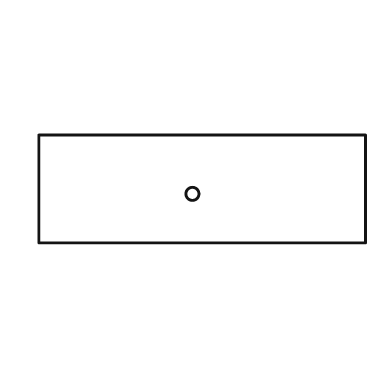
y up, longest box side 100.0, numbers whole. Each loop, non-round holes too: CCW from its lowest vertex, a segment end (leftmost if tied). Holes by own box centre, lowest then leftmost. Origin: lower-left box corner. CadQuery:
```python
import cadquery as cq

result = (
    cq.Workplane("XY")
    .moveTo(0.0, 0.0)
    .lineTo(100.0, 0.0)
    .lineTo(100.0, 33.0)
    .lineTo(0.0, 33.0)
    .close()
    .moveTo(47.0, 15.0)
    .circle(2.0)
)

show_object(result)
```